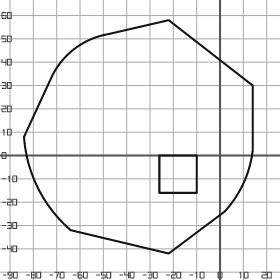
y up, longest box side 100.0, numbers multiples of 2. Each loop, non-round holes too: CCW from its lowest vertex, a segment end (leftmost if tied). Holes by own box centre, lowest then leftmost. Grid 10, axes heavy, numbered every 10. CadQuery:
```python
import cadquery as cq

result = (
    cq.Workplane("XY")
    .moveTo(-22.0, -42.0)
    .lineTo(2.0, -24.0)
    .threePointArc((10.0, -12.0), (14.0, 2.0))
    .lineTo(14.0, 30.0)
    .lineTo(-22.0, 58.0)
    .lineTo(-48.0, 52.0)
    .threePointArc((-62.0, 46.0), (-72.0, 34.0))
    .lineTo(-84.0, 8.0)
    .threePointArc((-78.0, -14.0), (-64.0, -32.0))
    .close()
    .moveTo(-26.0, -16.0)
    .lineTo(-10.0, -16.0)
    .lineTo(-10.0, 0.0)
    .lineTo(-26.0, 0.0)
    .close()
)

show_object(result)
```